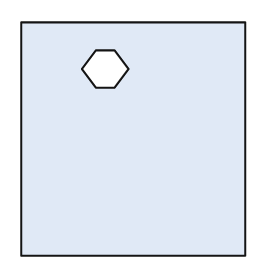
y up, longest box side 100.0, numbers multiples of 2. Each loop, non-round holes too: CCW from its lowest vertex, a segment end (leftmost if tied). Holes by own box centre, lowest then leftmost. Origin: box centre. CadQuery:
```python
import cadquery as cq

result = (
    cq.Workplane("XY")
    .moveTo(-48.0, -50.0)
    .lineTo(48.0, -50.0)
    .lineTo(48.0, 50.0)
    .lineTo(-48.0, 50.0)
    .close()
    .moveTo(-16.0, 22.0)
    .lineTo(-8.0, 22.0)
    .lineTo(-2.0, 30.0)
    .lineTo(-8.0, 38.0)
    .lineTo(-16.0, 38.0)
    .lineTo(-22.0, 30.0)
    .close()
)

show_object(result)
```